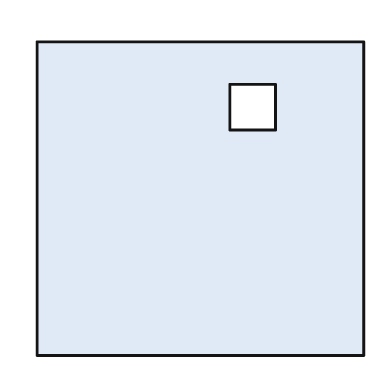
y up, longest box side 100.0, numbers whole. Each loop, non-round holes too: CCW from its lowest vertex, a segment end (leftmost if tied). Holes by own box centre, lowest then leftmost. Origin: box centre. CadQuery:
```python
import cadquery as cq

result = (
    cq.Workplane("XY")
    .moveTo(-50.0, -48.0)
    .lineTo(50.0, -48.0)
    .lineTo(50.0, 48.0)
    .lineTo(-50.0, 48.0)
    .close()
    .moveTo(9.0, 21.0)
    .lineTo(23.0, 21.0)
    .lineTo(23.0, 35.0)
    .lineTo(9.0, 35.0)
    .close()
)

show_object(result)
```